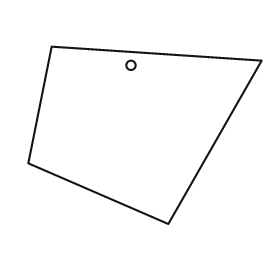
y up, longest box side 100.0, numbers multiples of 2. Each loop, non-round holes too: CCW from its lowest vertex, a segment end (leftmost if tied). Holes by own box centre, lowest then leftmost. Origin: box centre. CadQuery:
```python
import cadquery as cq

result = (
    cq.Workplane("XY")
    .moveTo(10.0, -38.0)
    .lineTo(50.0, 32.0)
    .lineTo(-40.0, 38.0)
    .lineTo(-50.0, -12.0)
    .close()
    .moveTo(-6.0, 30.0)
    .circle(2.0)
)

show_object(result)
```